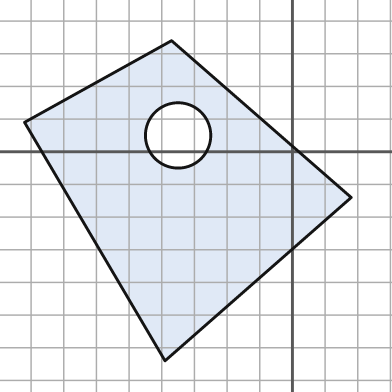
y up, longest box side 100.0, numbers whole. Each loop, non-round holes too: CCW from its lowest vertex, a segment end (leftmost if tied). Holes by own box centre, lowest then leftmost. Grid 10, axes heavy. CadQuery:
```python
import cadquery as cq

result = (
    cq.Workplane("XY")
    .moveTo(-39.0, -64.0)
    .lineTo(18.0, -14.0)
    .lineTo(-37.0, 34.0)
    .lineTo(-82.0, 9.0)
    .close()
    .moveTo(-35.0, 5.0)
    .circle(10.0)
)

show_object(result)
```